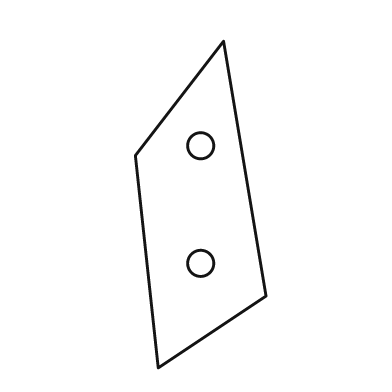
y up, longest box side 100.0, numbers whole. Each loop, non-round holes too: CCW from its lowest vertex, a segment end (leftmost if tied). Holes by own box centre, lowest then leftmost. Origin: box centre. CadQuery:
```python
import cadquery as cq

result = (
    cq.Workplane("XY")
    .moveTo(-13.0, -50.0)
    .lineTo(20.0, -28.0)
    .lineTo(7.0, 50.0)
    .lineTo(-20.0, 15.0)
    .close()
    .moveTo(0.0, -18.0)
    .circle(4.0)
    .moveTo(0.0, 18.0)
    .circle(4.0)
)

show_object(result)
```